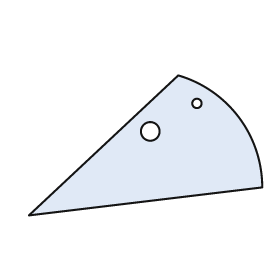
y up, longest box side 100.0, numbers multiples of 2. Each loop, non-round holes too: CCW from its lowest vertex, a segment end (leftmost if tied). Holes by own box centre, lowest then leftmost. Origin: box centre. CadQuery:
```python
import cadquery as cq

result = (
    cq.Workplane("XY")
    .moveTo(-50.0, -30.0)
    .lineTo(50.0, -18.0)
    .threePointArc((40.0, 12.0), (14.0, 30.0))
    .close()
    .moveTo(2.0, 6.0)
    .circle(4.0)
    .moveTo(22.0, 18.0)
    .circle(2.0)
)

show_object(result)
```